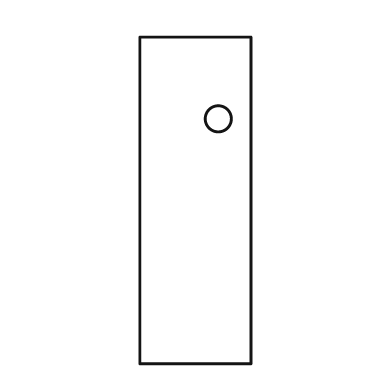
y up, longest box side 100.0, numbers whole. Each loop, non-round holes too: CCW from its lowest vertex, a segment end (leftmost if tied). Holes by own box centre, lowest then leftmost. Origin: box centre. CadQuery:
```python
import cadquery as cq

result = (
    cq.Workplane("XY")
    .moveTo(-17.0, -50.0)
    .lineTo(17.0, -50.0)
    .lineTo(17.0, 50.0)
    .lineTo(-17.0, 50.0)
    .close()
    .moveTo(7.0, 25.0)
    .circle(4.0)
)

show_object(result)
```